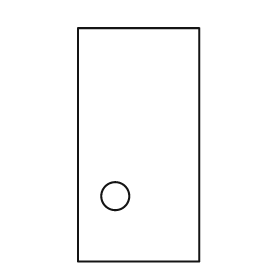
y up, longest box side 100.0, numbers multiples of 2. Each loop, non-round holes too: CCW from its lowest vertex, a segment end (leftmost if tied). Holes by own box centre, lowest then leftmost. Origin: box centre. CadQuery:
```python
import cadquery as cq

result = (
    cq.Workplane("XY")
    .moveTo(-26.0, -50.0)
    .lineTo(26.0, -50.0)
    .lineTo(26.0, 50.0)
    .lineTo(-26.0, 50.0)
    .close()
    .moveTo(-10.0, -22.0)
    .circle(6.0)
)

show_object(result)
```